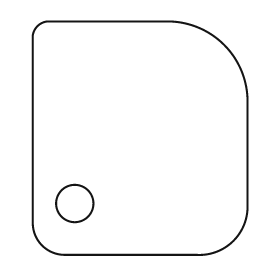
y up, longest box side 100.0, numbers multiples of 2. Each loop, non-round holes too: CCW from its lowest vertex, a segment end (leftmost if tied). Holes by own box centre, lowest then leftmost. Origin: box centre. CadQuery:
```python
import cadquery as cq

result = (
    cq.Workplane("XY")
    .moveTo(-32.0, -50.0)
    .lineTo(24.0, -50.0)
    .threePointArc((40.0, -44.0), (46.0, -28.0))
    .lineTo(46.0, 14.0)
    .threePointArc((36.0, 40.0), (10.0, 50.0))
    .lineTo(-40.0, 50.0)
    .threePointArc((-44.0, 48.0), (-46.0, 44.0))
    .lineTo(-46.0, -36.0)
    .threePointArc((-42.0, -46.0), (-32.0, -50.0))
    .close()
    .moveTo(-28.0, -28.0)
    .circle(8.0)
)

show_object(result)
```